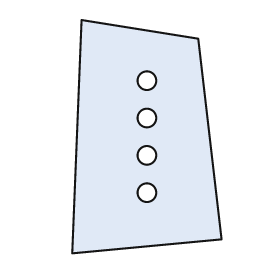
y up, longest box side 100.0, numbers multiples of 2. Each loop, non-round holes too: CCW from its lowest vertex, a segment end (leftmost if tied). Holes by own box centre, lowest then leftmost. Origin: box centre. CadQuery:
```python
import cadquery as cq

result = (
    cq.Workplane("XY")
    .moveTo(-32.0, -50.0)
    .lineTo(32.0, -44.0)
    .lineTo(22.0, 42.0)
    .lineTo(-28.0, 50.0)
    .close()
    .moveTo(0.0, -24.0)
    .circle(4.0)
    .moveTo(0.0, -8.0)
    .circle(4.0)
    .moveTo(0.0, 8.0)
    .circle(4.0)
    .moveTo(0.0, 24.0)
    .circle(4.0)
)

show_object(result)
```